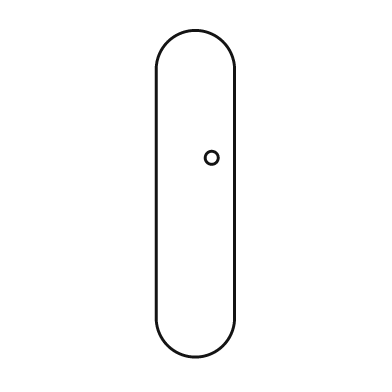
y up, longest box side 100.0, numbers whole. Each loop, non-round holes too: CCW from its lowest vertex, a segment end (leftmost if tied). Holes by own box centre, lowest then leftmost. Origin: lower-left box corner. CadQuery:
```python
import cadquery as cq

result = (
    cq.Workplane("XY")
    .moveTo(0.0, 12.0)
    .threePointArc((12.0, 0.0), (24.0, 12.0))
    .lineTo(24.0, 88.0)
    .threePointArc((12.0, 100.0), (0.0, 88.0))
    .close()
    .moveTo(17.0, 61.0)
    .circle(2.0)
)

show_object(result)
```